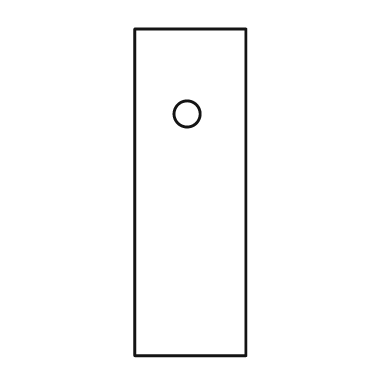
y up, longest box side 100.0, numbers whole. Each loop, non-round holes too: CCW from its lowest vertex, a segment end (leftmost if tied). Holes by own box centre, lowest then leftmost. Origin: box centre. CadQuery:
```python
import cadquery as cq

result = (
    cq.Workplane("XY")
    .moveTo(-17.0, -50.0)
    .lineTo(17.0, -50.0)
    .lineTo(17.0, 50.0)
    .lineTo(-17.0, 50.0)
    .close()
    .moveTo(-1.0, 24.0)
    .circle(4.0)
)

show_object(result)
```